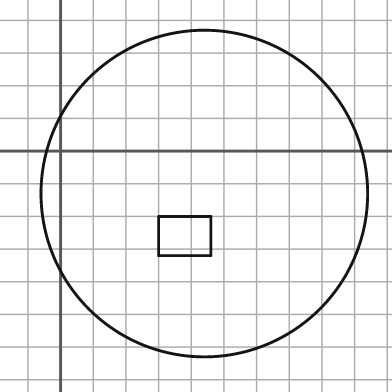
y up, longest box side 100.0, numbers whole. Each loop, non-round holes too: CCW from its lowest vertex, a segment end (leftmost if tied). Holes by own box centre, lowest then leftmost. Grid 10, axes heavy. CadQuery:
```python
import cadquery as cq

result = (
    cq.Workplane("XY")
    .moveTo(44.0, -13.0)
    .circle(50.0)
    .moveTo(30.0, -32.0)
    .lineTo(46.0, -32.0)
    .lineTo(46.0, -20.0)
    .lineTo(30.0, -20.0)
    .close()
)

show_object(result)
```